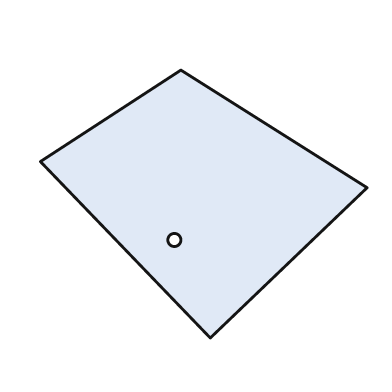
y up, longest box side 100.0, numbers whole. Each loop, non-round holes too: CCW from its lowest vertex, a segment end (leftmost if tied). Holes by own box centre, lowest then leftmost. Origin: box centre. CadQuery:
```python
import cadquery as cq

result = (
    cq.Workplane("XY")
    .moveTo(2.0, -41.0)
    .lineTo(50.0, 5.0)
    .lineTo(-7.0, 41.0)
    .lineTo(-50.0, 13.0)
    .close()
    .moveTo(-9.0, -11.0)
    .circle(2.0)
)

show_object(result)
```